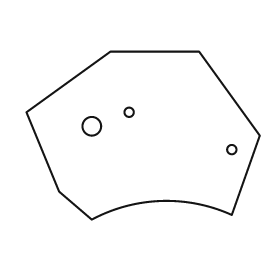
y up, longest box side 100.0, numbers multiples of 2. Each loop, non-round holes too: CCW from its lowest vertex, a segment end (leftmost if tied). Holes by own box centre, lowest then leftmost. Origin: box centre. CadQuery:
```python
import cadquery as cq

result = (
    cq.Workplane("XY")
    .moveTo(-22.0, -36.0)
    .threePointArc((8.0, -28.0), (38.0, -34.0))
    .lineTo(50.0, 0.0)
    .lineTo(24.0, 36.0)
    .lineTo(-14.0, 36.0)
    .lineTo(-50.0, 10.0)
    .lineTo(-36.0, -24.0)
    .close()
    .moveTo(38.0, -6.0)
    .circle(2.0)
    .moveTo(-22.0, 4.0)
    .circle(4.0)
    .moveTo(-6.0, 10.0)
    .circle(2.0)
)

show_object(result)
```